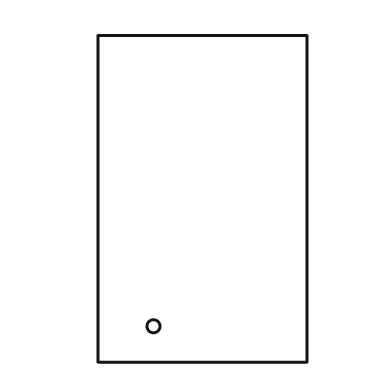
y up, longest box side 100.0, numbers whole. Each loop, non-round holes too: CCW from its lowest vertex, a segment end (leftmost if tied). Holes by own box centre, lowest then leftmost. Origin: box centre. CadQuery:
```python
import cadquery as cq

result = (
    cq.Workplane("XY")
    .moveTo(-32.0, -50.0)
    .lineTo(32.0, -50.0)
    .lineTo(32.0, 50.0)
    .lineTo(-32.0, 50.0)
    .close()
    .moveTo(-15.0, -39.0)
    .circle(2.0)
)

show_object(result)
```